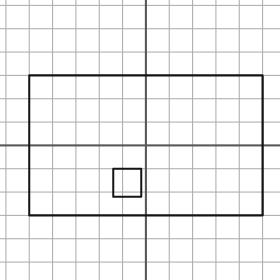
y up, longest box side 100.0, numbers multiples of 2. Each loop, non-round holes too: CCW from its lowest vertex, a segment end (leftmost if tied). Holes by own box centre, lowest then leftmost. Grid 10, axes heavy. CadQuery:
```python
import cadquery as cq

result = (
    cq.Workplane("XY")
    .moveTo(-50.0, -30.0)
    .lineTo(50.0, -30.0)
    .lineTo(50.0, 30.0)
    .lineTo(-50.0, 30.0)
    .close()
    .moveTo(-14.0, -22.0)
    .lineTo(-2.0, -22.0)
    .lineTo(-2.0, -10.0)
    .lineTo(-14.0, -10.0)
    .close()
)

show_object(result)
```